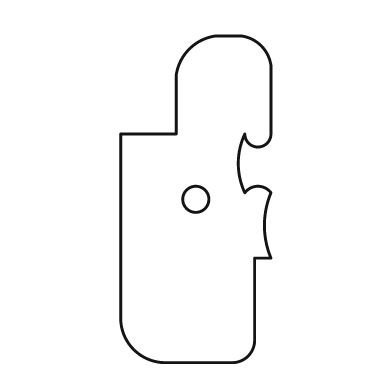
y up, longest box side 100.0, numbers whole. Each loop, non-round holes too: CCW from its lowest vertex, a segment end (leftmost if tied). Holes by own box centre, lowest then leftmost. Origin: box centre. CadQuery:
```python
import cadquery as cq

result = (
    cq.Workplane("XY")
    .moveTo(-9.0, -50.0)
    .lineTo(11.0, -50.0)
    .threePointArc((16.0, -48.0), (18.0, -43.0))
    .lineTo(18.0, -18.0)
    .lineTo(23.0, -18.0)
    .threePointArc((21.0, -8.0), (23.0, 2.0))
    .threePointArc((19.0, 4.0), (15.0, 2.0))
    .threePointArc((13.0, 11.0), (15.0, 20.0))
    .threePointArc((19.0, 16.0), (23.0, 20.0))
    .lineTo(23.0, 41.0)
    .threePointArc((20.0, 47.0), (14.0, 50.0))
    .lineTo(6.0, 50.0)
    .threePointArc((-2.0, 46.0), (-6.0, 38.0))
    .lineTo(-6.0, 20.0)
    .lineTo(-23.0, 20.0)
    .lineTo(-23.0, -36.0)
    .threePointArc((-19.0, -46.0), (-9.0, -50.0))
    .close()
    .moveTo(0.0, 0.0)
    .circle(4.0)
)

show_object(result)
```